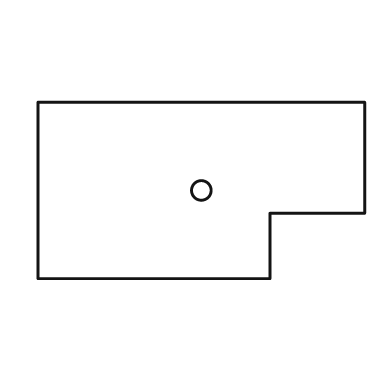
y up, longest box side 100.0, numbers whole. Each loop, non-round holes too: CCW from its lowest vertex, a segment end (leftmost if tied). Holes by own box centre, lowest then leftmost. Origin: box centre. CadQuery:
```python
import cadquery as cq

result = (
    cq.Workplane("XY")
    .moveTo(-50.0, -27.0)
    .lineTo(21.0, -27.0)
    .lineTo(21.0, -7.0)
    .lineTo(50.0, -7.0)
    .lineTo(50.0, 27.0)
    .lineTo(-50.0, 27.0)
    .close()
    .moveTo(0.0, 0.0)
    .circle(3.0)
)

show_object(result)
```